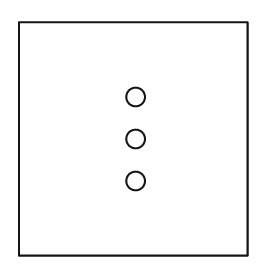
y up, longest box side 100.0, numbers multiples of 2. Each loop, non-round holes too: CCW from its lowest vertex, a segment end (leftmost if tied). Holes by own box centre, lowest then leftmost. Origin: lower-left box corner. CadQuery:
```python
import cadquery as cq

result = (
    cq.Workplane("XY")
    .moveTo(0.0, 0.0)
    .lineTo(98.0, 0.0)
    .lineTo(98.0, 100.0)
    .lineTo(0.0, 100.0)
    .close()
    .moveTo(50.0, 32.0)
    .circle(4.0)
    .moveTo(50.0, 50.0)
    .circle(4.0)
    .moveTo(50.0, 68.0)
    .circle(4.0)
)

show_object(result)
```